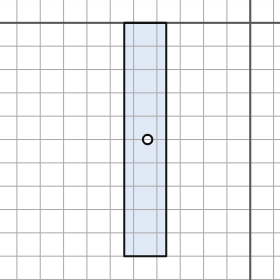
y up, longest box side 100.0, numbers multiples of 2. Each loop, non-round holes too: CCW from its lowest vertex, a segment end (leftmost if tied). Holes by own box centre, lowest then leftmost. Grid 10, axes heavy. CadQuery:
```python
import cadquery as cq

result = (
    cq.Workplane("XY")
    .moveTo(-54.0, -100.0)
    .lineTo(-36.0, -100.0)
    .lineTo(-36.0, 0.0)
    .lineTo(-54.0, 0.0)
    .close()
    .moveTo(-44.0, -50.0)
    .circle(2.0)
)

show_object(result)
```